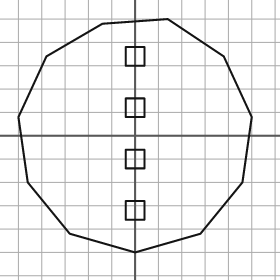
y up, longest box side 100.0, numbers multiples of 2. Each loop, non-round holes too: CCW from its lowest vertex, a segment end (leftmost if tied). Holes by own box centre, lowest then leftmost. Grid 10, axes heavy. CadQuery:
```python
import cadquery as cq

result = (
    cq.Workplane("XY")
    .moveTo(0.0, -50.0)
    .lineTo(28.0, -42.0)
    .lineTo(46.0, -20.0)
    .lineTo(50.0, 8.0)
    .lineTo(38.0, 34.0)
    .lineTo(14.0, 50.0)
    .lineTo(-14.0, 48.0)
    .lineTo(-38.0, 34.0)
    .lineTo(-50.0, 8.0)
    .lineTo(-46.0, -20.0)
    .lineTo(-28.0, -42.0)
    .close()
    .moveTo(-4.0, -36.0)
    .lineTo(4.0, -36.0)
    .lineTo(4.0, -28.0)
    .lineTo(-4.0, -28.0)
    .close()
    .moveTo(-4.0, -14.0)
    .lineTo(4.0, -14.0)
    .lineTo(4.0, -6.0)
    .lineTo(-4.0, -6.0)
    .close()
    .moveTo(-4.0, 8.0)
    .lineTo(4.0, 8.0)
    .lineTo(4.0, 16.0)
    .lineTo(-4.0, 16.0)
    .close()
    .moveTo(-4.0, 30.0)
    .lineTo(4.0, 30.0)
    .lineTo(4.0, 38.0)
    .lineTo(-4.0, 38.0)
    .close()
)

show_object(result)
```